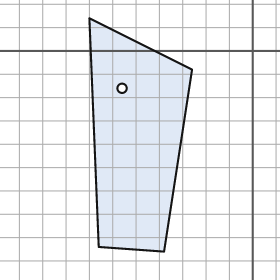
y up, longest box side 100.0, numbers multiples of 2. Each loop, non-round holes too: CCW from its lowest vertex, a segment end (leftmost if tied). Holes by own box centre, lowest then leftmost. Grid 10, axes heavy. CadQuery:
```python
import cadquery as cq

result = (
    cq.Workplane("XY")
    .moveTo(-38.0, -86.0)
    .lineTo(-26.0, -8.0)
    .lineTo(-70.0, 14.0)
    .lineTo(-66.0, -84.0)
    .close()
    .moveTo(-56.0, -16.0)
    .circle(2.0)
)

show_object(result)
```